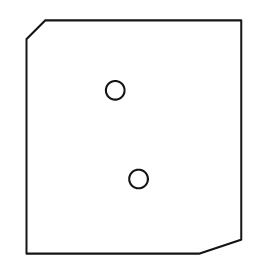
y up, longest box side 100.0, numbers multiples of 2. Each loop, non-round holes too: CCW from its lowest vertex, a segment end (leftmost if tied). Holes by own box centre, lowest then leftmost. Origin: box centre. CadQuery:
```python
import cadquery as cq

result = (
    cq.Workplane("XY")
    .moveTo(-46.0, -50.0)
    .lineTo(28.0, -50.0)
    .lineTo(46.0, -44.0)
    .lineTo(46.0, 50.0)
    .lineTo(-38.0, 50.0)
    .lineTo(-46.0, 42.0)
    .close()
    .moveTo(2.0, -18.0)
    .circle(4.0)
    .moveTo(-8.0, 20.0)
    .circle(4.0)
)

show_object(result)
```